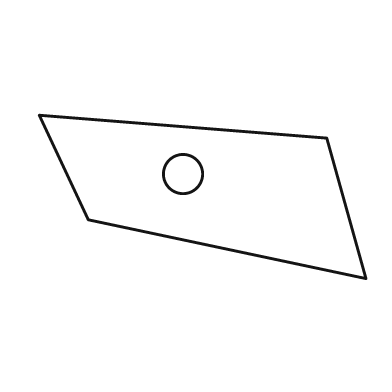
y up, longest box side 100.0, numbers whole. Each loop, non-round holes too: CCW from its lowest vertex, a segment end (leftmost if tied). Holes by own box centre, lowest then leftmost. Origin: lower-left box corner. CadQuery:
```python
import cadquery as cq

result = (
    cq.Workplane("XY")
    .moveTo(100.0, 0.0)
    .lineTo(88.0, 43.0)
    .lineTo(0.0, 50.0)
    .lineTo(15.0, 18.0)
    .close()
    .moveTo(44.0, 32.0)
    .circle(6.0)
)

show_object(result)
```